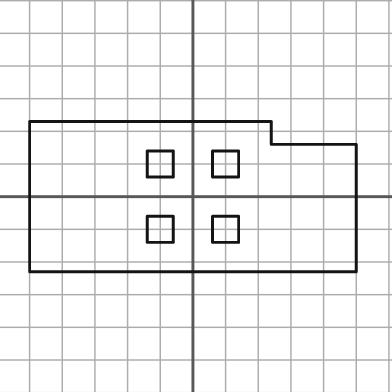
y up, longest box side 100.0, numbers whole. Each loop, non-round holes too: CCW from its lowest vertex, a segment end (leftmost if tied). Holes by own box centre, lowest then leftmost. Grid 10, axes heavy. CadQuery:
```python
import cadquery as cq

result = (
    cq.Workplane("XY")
    .moveTo(-50.0, -23.0)
    .lineTo(50.0, -23.0)
    .lineTo(50.0, 16.0)
    .lineTo(24.0, 16.0)
    .lineTo(24.0, 23.0)
    .lineTo(-50.0, 23.0)
    .close()
    .moveTo(-14.0, -14.0)
    .lineTo(-6.0, -14.0)
    .lineTo(-6.0, -6.0)
    .lineTo(-14.0, -6.0)
    .close()
    .moveTo(6.0, -14.0)
    .lineTo(14.0, -14.0)
    .lineTo(14.0, -6.0)
    .lineTo(6.0, -6.0)
    .close()
    .moveTo(-14.0, 6.0)
    .lineTo(-6.0, 6.0)
    .lineTo(-6.0, 14.0)
    .lineTo(-14.0, 14.0)
    .close()
    .moveTo(6.0, 6.0)
    .lineTo(14.0, 6.0)
    .lineTo(14.0, 14.0)
    .lineTo(6.0, 14.0)
    .close()
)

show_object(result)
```